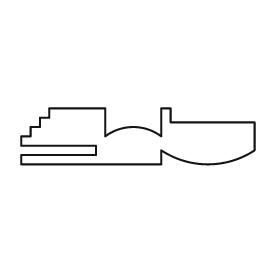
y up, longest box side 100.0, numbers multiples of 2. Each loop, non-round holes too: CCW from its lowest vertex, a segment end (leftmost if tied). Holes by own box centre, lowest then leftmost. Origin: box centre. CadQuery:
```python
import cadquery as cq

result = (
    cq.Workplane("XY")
    .moveTo(-50.0, -12.0)
    .lineTo(10.0, -12.0)
    .lineTo(10.0, -6.0)
    .threePointArc((30.0, -12.0), (50.0, -6.0))
    .lineTo(50.0, 6.0)
    .lineTo(14.0, 6.0)
    .lineTo(14.0, 12.0)
    .lineTo(10.0, 12.0)
    .lineTo(10.0, 0.0)
    .threePointArc((-2.0, 4.0), (-14.0, 0.0))
    .lineTo(-14.0, 12.0)
    .lineTo(-38.0, 12.0)
    .lineTo(-38.0, 8.0)
    .lineTo(-42.0, 8.0)
    .lineTo(-42.0, 4.0)
    .lineTo(-46.0, 4.0)
    .lineTo(-46.0, 0.0)
    .lineTo(-50.0, 0.0)
    .lineTo(-50.0, -4.0)
    .lineTo(-18.0, -4.0)
    .lineTo(-18.0, -8.0)
    .lineTo(-50.0, -8.0)
    .close()
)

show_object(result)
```